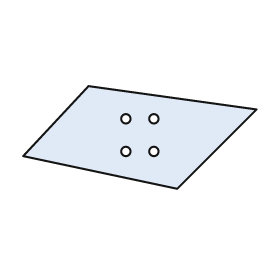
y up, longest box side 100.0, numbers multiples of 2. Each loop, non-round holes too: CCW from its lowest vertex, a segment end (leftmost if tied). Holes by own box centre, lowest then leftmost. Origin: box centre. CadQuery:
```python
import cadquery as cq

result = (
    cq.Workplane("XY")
    .moveTo(16.0, -22.0)
    .lineTo(50.0, 12.0)
    .lineTo(-22.0, 22.0)
    .lineTo(-50.0, -8.0)
    .close()
    .moveTo(-6.0, -6.0)
    .circle(2.0)
    .moveTo(6.0, -6.0)
    .circle(2.0)
    .moveTo(-6.0, 8.0)
    .circle(2.0)
    .moveTo(6.0, 8.0)
    .circle(2.0)
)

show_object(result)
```